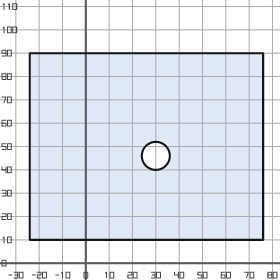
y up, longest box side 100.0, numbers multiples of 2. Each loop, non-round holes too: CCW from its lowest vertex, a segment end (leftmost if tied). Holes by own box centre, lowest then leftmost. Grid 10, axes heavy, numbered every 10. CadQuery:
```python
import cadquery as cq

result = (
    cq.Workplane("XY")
    .moveTo(-24.0, 10.0)
    .lineTo(76.0, 10.0)
    .lineTo(76.0, 90.0)
    .lineTo(-24.0, 90.0)
    .close()
    .moveTo(30.0, 46.0)
    .circle(6.0)
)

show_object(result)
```